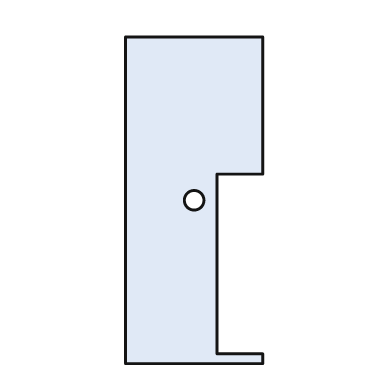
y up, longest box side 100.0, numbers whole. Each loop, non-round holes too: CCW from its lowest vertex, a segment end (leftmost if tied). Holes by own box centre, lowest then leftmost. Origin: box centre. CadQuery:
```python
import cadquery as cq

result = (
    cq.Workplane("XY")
    .moveTo(-21.0, -50.0)
    .lineTo(21.0, -50.0)
    .lineTo(21.0, -47.0)
    .lineTo(7.0, -47.0)
    .lineTo(7.0, 8.0)
    .lineTo(21.0, 8.0)
    .lineTo(21.0, 50.0)
    .lineTo(-21.0, 50.0)
    .close()
    .moveTo(0.0, 0.0)
    .circle(3.0)
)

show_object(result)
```